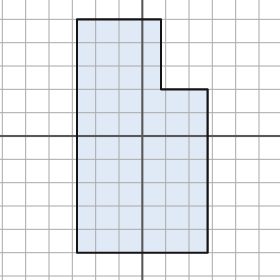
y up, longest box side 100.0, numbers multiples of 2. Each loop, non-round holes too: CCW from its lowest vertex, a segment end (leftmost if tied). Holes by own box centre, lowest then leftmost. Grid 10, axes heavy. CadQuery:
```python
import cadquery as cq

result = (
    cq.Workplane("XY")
    .moveTo(-28.0, -50.0)
    .lineTo(28.0, -50.0)
    .lineTo(28.0, 20.0)
    .lineTo(8.0, 20.0)
    .lineTo(8.0, 50.0)
    .lineTo(-28.0, 50.0)
    .close()
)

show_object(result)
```